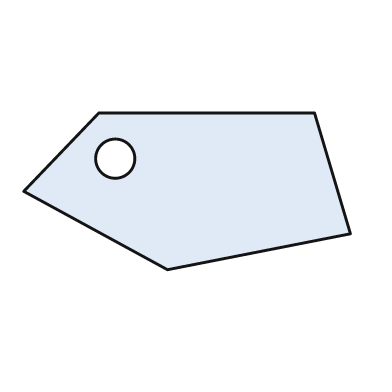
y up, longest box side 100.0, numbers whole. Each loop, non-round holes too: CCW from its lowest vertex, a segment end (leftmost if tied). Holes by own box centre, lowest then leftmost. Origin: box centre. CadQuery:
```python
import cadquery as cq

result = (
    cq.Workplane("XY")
    .moveTo(-6.0, -24.0)
    .lineTo(50.0, -13.0)
    .lineTo(39.0, 24.0)
    .lineTo(-27.0, 24.0)
    .lineTo(-50.0, 0.0)
    .close()
    .moveTo(-22.0, 10.0)
    .circle(6.0)
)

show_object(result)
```